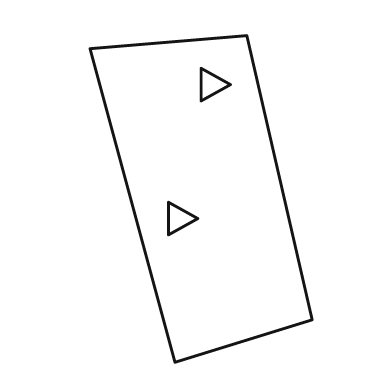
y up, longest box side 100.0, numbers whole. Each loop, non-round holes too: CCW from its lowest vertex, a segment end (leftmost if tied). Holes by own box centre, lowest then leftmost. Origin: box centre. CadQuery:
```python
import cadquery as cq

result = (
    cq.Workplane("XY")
    .moveTo(-8.0, -50.0)
    .lineTo(34.0, -37.0)
    .lineTo(14.0, 50.0)
    .lineTo(-34.0, 46.0)
    .close()
    .moveTo(-10.0, -11.0)
    .lineTo(-1.0, -6.0)
    .lineTo(-10.0, -1.0)
    .close()
    .moveTo(0.0, 30.0)
    .lineTo(9.0, 35.0)
    .lineTo(0.0, 40.0)
    .close()
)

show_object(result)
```